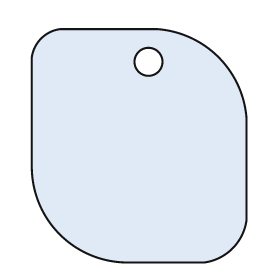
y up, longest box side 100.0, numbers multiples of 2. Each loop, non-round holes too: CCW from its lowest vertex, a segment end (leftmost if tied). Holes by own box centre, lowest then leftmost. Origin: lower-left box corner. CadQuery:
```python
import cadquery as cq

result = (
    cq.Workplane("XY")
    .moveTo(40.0, 0.0)
    .lineTo(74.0, 0.0)
    .threePointArc((86.0, 6.0), (92.0, 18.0))
    .lineTo(92.0, 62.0)
    .threePointArc((80.0, 88.0), (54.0, 100.0))
    .lineTo(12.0, 100.0)
    .threePointArc((4.0, 96.0), (0.0, 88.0))
    .lineTo(0.0, 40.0)
    .threePointArc((12.0, 12.0), (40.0, 0.0))
    .close()
    .moveTo(50.0, 86.0)
    .circle(6.0)
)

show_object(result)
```